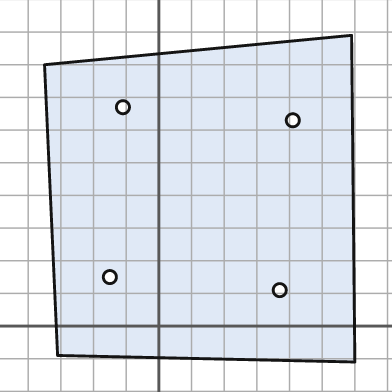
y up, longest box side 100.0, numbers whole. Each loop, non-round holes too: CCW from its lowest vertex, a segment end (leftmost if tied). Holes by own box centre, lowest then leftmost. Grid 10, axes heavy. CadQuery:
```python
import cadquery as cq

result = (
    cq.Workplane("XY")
    .moveTo(60.0, -11.0)
    .lineTo(59.0, 89.0)
    .lineTo(-35.0, 80.0)
    .lineTo(-31.0, -9.0)
    .close()
    .moveTo(37.0, 11.0)
    .circle(2.0)
    .moveTo(-15.0, 15.0)
    .circle(2.0)
    .moveTo(41.0, 63.0)
    .circle(2.0)
    .moveTo(-11.0, 67.0)
    .circle(2.0)
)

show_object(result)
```